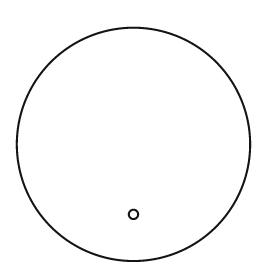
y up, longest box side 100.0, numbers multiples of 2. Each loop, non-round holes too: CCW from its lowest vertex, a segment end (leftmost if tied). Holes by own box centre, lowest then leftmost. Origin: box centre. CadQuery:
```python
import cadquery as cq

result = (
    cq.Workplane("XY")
    .moveTo(0.0, 0.0)
    .circle(50.0)
    .moveTo(0.0, -30.0)
    .circle(2.0)
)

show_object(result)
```